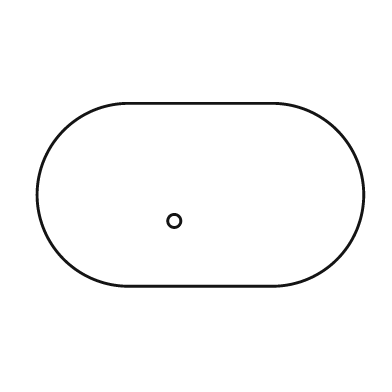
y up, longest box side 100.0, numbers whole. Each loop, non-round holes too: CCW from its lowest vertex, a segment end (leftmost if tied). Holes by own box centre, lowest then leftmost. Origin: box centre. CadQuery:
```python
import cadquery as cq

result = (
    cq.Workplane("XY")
    .moveTo(-22.0, -28.0)
    .lineTo(22.0, -28.0)
    .threePointArc((50.0, 0.0), (22.0, 28.0))
    .lineTo(-22.0, 28.0)
    .threePointArc((-50.0, 0.0), (-22.0, -28.0))
    .close()
    .moveTo(-8.0, -8.0)
    .circle(2.0)
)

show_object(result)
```